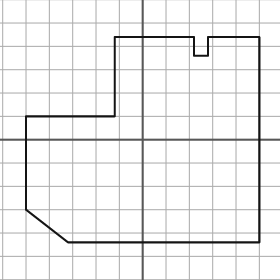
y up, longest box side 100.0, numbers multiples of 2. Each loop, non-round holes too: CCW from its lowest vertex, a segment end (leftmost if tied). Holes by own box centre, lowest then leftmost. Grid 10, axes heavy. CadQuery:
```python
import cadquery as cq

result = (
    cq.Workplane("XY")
    .moveTo(-32.0, -44.0)
    .lineTo(50.0, -44.0)
    .lineTo(50.0, 44.0)
    .lineTo(28.0, 44.0)
    .lineTo(28.0, 36.0)
    .lineTo(22.0, 36.0)
    .lineTo(22.0, 44.0)
    .lineTo(-12.0, 44.0)
    .lineTo(-12.0, 10.0)
    .lineTo(-50.0, 10.0)
    .lineTo(-50.0, -30.0)
    .close()
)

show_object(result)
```